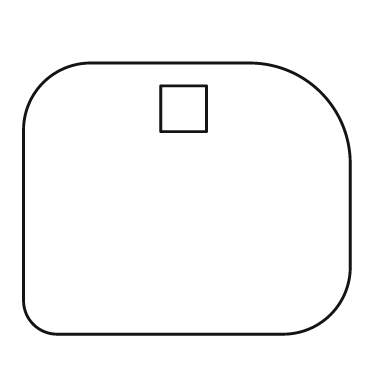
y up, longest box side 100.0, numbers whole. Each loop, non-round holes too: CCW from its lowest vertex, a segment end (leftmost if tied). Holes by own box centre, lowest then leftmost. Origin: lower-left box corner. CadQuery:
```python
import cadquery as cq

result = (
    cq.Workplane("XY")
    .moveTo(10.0, 0.0)
    .lineTo(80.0, 0.0)
    .threePointArc((94.0, 6.0), (100.0, 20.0))
    .lineTo(100.0, 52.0)
    .threePointArc((91.0, 74.0), (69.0, 83.0))
    .lineTo(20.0, 83.0)
    .threePointArc((6.0, 77.0), (0.0, 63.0))
    .lineTo(0.0, 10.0)
    .threePointArc((3.0, 3.0), (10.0, 0.0))
    .close()
    .moveTo(42.0, 62.0)
    .lineTo(56.0, 62.0)
    .lineTo(56.0, 76.0)
    .lineTo(42.0, 76.0)
    .close()
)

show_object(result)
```